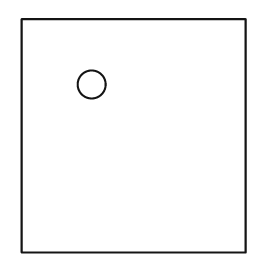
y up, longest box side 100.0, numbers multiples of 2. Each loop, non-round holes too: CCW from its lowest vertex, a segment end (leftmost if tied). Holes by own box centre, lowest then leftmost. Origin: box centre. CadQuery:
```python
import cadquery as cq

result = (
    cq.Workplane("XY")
    .moveTo(-48.0, -50.0)
    .lineTo(48.0, -50.0)
    .lineTo(48.0, 50.0)
    .lineTo(-48.0, 50.0)
    .close()
    .moveTo(-18.0, 22.0)
    .circle(6.0)
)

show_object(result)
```